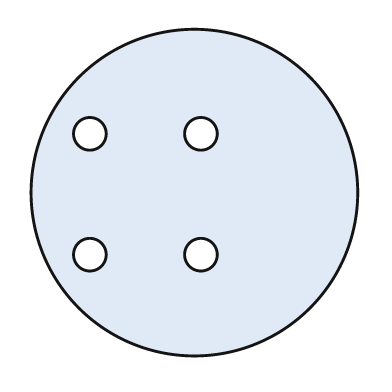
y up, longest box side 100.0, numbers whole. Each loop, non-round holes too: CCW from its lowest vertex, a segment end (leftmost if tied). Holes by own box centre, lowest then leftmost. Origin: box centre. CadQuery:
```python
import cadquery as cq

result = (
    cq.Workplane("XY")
    .moveTo(0.0, 0.0)
    .circle(50.0)
    .moveTo(-32.0, -19.0)
    .circle(5.0)
    .moveTo(2.0, -19.0)
    .circle(5.0)
    .moveTo(-32.0, 18.0)
    .circle(5.0)
    .moveTo(2.0, 18.0)
    .circle(5.0)
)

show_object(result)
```